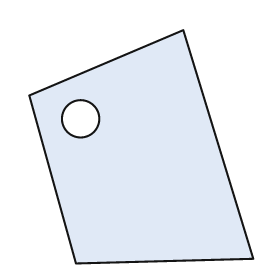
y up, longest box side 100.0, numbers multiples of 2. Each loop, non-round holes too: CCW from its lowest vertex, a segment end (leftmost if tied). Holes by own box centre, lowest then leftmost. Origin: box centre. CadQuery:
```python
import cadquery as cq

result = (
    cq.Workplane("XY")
    .moveTo(-28.0, -50.0)
    .lineTo(48.0, -48.0)
    .lineTo(18.0, 50.0)
    .lineTo(-48.0, 22.0)
    .close()
    .moveTo(-26.0, 12.0)
    .circle(8.0)
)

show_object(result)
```